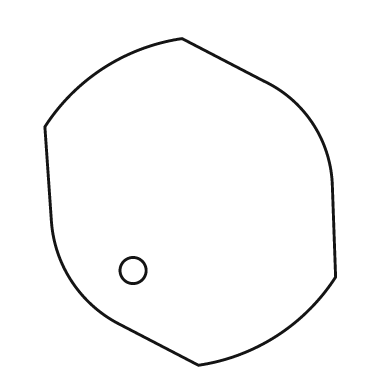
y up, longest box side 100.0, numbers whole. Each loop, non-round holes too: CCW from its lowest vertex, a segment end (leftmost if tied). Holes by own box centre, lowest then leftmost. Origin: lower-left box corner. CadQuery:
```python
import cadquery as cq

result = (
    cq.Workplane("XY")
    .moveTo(47.0, 0.0)
    .threePointArc((71.0, 9.0), (89.0, 27.0))
    .lineTo(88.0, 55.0)
    .threePointArc((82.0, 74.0), (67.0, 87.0))
    .lineTo(42.0, 100.0)
    .threePointArc((18.0, 91.0), (0.0, 73.0))
    .lineTo(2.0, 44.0)
    .threePointArc((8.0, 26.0), (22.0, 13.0))
    .close()
    .moveTo(27.0, 29.0)
    .circle(4.0)
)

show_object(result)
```